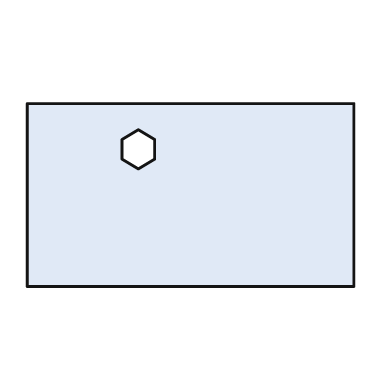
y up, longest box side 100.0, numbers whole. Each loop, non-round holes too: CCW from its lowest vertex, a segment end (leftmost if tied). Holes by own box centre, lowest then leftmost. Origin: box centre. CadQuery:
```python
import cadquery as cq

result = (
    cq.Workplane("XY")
    .moveTo(-50.0, -28.0)
    .lineTo(50.0, -28.0)
    .lineTo(50.0, 28.0)
    .lineTo(-50.0, 28.0)
    .close()
    .moveTo(-16.0, 8.0)
    .lineTo(-11.0, 11.0)
    .lineTo(-11.0, 17.0)
    .lineTo(-16.0, 20.0)
    .lineTo(-21.0, 17.0)
    .lineTo(-21.0, 11.0)
    .close()
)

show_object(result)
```